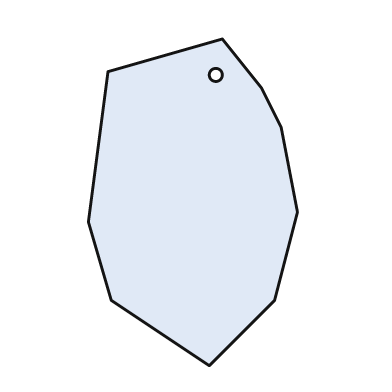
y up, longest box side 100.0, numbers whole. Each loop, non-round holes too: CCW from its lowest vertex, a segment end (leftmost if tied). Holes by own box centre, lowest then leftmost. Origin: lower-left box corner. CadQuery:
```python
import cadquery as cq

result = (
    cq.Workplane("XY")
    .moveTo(37.0, 0.0)
    .lineTo(57.0, 20.0)
    .lineTo(64.0, 47.0)
    .lineTo(59.0, 73.0)
    .lineTo(53.0, 85.0)
    .lineTo(41.0, 100.0)
    .lineTo(6.0, 90.0)
    .lineTo(0.0, 44.0)
    .lineTo(7.0, 20.0)
    .close()
    .moveTo(39.0, 89.0)
    .circle(2.0)
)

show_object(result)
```